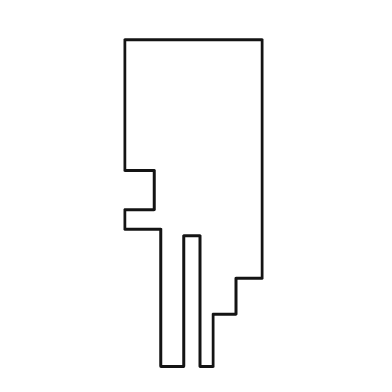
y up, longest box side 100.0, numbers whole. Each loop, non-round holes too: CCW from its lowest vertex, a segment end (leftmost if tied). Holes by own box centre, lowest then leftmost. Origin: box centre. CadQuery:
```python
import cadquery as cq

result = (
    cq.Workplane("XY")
    .moveTo(-10.0, -50.0)
    .lineTo(-3.0, -50.0)
    .lineTo(-3.0, -10.0)
    .lineTo(2.0, -10.0)
    .lineTo(2.0, -50.0)
    .lineTo(6.0, -50.0)
    .lineTo(6.0, -34.0)
    .lineTo(13.0, -34.0)
    .lineTo(13.0, -23.0)
    .lineTo(21.0, -23.0)
    .lineTo(21.0, 50.0)
    .lineTo(-21.0, 50.0)
    .lineTo(-21.0, 10.0)
    .lineTo(-12.0, 10.0)
    .lineTo(-12.0, -2.0)
    .lineTo(-21.0, -2.0)
    .lineTo(-21.0, -8.0)
    .lineTo(-10.0, -8.0)
    .close()
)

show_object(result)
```